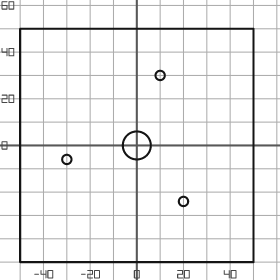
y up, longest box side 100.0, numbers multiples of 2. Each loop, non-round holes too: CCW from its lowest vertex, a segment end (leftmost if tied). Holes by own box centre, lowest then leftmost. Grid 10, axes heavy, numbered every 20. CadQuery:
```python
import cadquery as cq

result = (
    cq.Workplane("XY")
    .moveTo(-50.0, -50.0)
    .lineTo(50.0, -50.0)
    .lineTo(50.0, 50.0)
    .lineTo(-50.0, 50.0)
    .close()
    .moveTo(20.0, -24.0)
    .circle(2.0)
    .moveTo(-30.0, -6.0)
    .circle(2.0)
    .moveTo(0.0, 0.0)
    .circle(6.0)
    .moveTo(10.0, 30.0)
    .circle(2.0)
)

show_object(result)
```